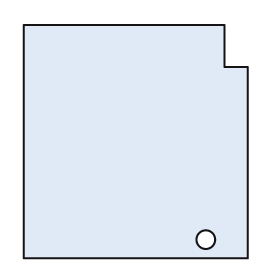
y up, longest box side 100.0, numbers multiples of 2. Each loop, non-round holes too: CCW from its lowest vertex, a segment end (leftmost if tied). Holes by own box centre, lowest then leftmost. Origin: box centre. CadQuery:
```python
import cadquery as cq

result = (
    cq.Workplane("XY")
    .moveTo(-48.0, -50.0)
    .lineTo(48.0, -50.0)
    .lineTo(48.0, 32.0)
    .lineTo(38.0, 32.0)
    .lineTo(38.0, 50.0)
    .lineTo(-48.0, 50.0)
    .close()
    .moveTo(30.0, -42.0)
    .circle(4.0)
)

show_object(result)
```